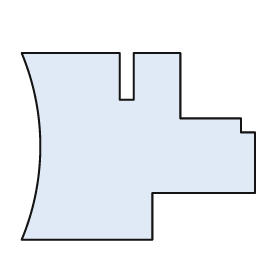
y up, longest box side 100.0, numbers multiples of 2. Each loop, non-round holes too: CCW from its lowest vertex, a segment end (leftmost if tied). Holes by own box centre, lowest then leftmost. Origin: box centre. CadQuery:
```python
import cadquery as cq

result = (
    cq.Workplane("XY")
    .moveTo(-50.0, -40.0)
    .lineTo(6.0, -40.0)
    .lineTo(6.0, -20.0)
    .lineTo(50.0, -20.0)
    .lineTo(50.0, 6.0)
    .lineTo(44.0, 6.0)
    .lineTo(44.0, 12.0)
    .lineTo(18.0, 12.0)
    .lineTo(18.0, 40.0)
    .lineTo(-2.0, 40.0)
    .lineTo(-2.0, 20.0)
    .lineTo(-8.0, 20.0)
    .lineTo(-8.0, 40.0)
    .lineTo(-50.0, 40.0)
    .threePointArc((-42.0, 0.0), (-50.0, -40.0))
    .close()
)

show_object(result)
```